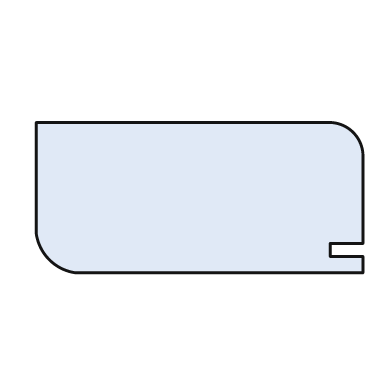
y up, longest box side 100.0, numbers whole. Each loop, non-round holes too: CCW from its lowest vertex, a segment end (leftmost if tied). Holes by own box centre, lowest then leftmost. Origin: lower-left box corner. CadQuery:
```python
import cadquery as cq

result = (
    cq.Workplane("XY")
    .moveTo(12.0, 0.0)
    .lineTo(100.0, 0.0)
    .lineTo(100.0, 5.0)
    .lineTo(90.0, 5.0)
    .lineTo(90.0, 9.0)
    .lineTo(100.0, 9.0)
    .lineTo(100.0, 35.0)
    .threePointArc((97.0, 43.0), (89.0, 46.0))
    .lineTo(0.0, 46.0)
    .lineTo(0.0, 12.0)
    .threePointArc((4.0, 4.0), (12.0, 0.0))
    .close()
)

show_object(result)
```